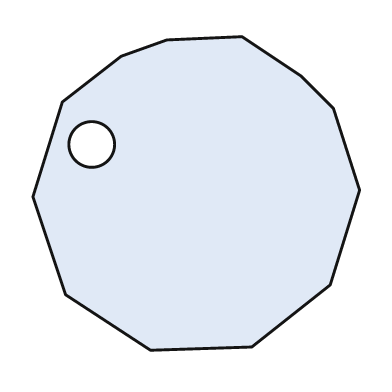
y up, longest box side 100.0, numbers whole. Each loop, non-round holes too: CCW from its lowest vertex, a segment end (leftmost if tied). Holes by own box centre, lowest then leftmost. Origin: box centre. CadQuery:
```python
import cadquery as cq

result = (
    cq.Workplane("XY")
    .moveTo(-14.0, -48.0)
    .lineTo(17.0, -47.0)
    .lineTo(41.0, -28.0)
    .lineTo(50.0, 1.0)
    .lineTo(42.0, 26.0)
    .lineTo(32.0, 36.0)
    .lineTo(14.0, 48.0)
    .lineTo(-9.0, 47.0)
    .lineTo(-23.0, 42.0)
    .lineTo(-41.0, 28.0)
    .lineTo(-50.0, -1.0)
    .lineTo(-40.0, -31.0)
    .close()
    .moveTo(-32.0, 15.0)
    .circle(7.0)
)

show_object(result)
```